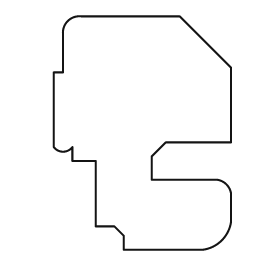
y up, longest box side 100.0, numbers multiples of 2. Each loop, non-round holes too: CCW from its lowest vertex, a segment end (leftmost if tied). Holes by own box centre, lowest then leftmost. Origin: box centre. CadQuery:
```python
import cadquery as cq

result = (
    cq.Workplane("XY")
    .moveTo(-8.0, -50.0)
    .lineTo(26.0, -50.0)
    .threePointArc((34.0, -46.0), (38.0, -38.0))
    .lineTo(38.0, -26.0)
    .threePointArc((36.0, -22.0), (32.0, -20.0))
    .lineTo(4.0, -20.0)
    .lineTo(4.0, -10.0)
    .lineTo(10.0, -4.0)
    .lineTo(38.0, -4.0)
    .lineTo(38.0, 28.0)
    .lineTo(16.0, 50.0)
    .lineTo(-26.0, 50.0)
    .threePointArc((-32.0, 48.0), (-34.0, 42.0))
    .lineTo(-34.0, 26.0)
    .lineTo(-38.0, 26.0)
    .lineTo(-38.0, -6.0)
    .threePointArc((-34.0, -8.0), (-30.0, -6.0))
    .lineTo(-30.0, -12.0)
    .lineTo(-20.0, -12.0)
    .lineTo(-20.0, -40.0)
    .lineTo(-12.0, -40.0)
    .lineTo(-8.0, -44.0)
    .close()
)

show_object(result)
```